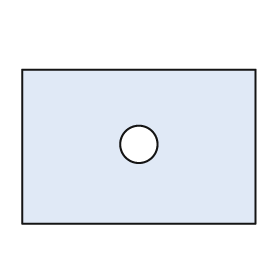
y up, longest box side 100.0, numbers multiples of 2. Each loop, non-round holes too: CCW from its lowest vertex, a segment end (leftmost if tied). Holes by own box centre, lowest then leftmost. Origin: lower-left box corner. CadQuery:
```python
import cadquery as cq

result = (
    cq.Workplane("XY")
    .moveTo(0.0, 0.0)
    .lineTo(100.0, 0.0)
    .lineTo(100.0, 66.0)
    .lineTo(0.0, 66.0)
    .close()
    .moveTo(50.0, 34.0)
    .circle(8.0)
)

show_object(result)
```